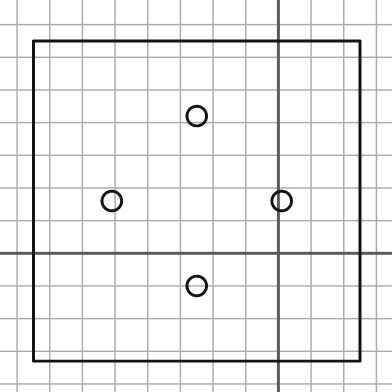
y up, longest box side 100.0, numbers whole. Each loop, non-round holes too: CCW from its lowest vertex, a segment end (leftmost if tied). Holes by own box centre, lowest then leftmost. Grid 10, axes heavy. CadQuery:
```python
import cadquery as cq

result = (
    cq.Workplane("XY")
    .moveTo(-75.0, -33.0)
    .lineTo(25.0, -33.0)
    .lineTo(25.0, 65.0)
    .lineTo(-75.0, 65.0)
    .close()
    .moveTo(-25.0, -10.0)
    .circle(3.0)
    .moveTo(-51.0, 16.0)
    .circle(3.0)
    .moveTo(1.0, 16.0)
    .circle(3.0)
    .moveTo(-25.0, 42.0)
    .circle(3.0)
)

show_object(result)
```